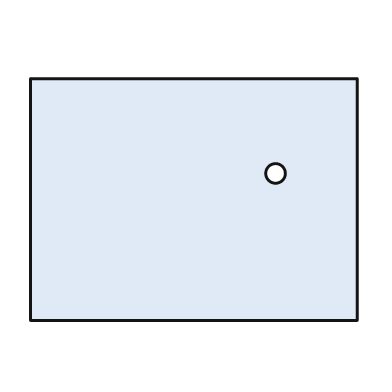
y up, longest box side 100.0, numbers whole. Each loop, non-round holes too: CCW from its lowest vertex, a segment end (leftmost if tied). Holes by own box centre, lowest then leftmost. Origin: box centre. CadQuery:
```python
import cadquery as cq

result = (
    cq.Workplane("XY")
    .moveTo(-50.0, -37.0)
    .lineTo(50.0, -37.0)
    .lineTo(50.0, 37.0)
    .lineTo(-50.0, 37.0)
    .close()
    .moveTo(25.0, 8.0)
    .circle(3.0)
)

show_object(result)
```